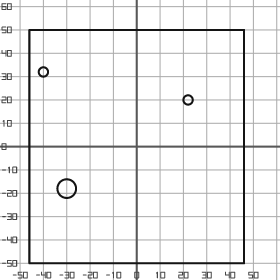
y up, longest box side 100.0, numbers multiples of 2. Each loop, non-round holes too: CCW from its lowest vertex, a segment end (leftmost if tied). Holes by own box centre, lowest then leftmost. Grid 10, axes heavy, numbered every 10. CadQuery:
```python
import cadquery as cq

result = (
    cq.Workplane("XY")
    .moveTo(-46.0, -50.0)
    .lineTo(46.0, -50.0)
    .lineTo(46.0, 50.0)
    .lineTo(-46.0, 50.0)
    .close()
    .moveTo(-30.0, -18.0)
    .circle(4.0)
    .moveTo(22.0, 20.0)
    .circle(2.0)
    .moveTo(-40.0, 32.0)
    .circle(2.0)
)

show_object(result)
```